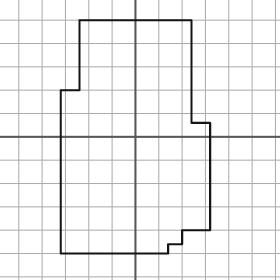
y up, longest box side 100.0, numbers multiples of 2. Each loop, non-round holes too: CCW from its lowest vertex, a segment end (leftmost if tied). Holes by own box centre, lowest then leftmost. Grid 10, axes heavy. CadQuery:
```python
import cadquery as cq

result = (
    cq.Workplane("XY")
    .moveTo(-32.0, -50.0)
    .lineTo(14.0, -50.0)
    .lineTo(14.0, -46.0)
    .lineTo(20.0, -46.0)
    .lineTo(20.0, -40.0)
    .lineTo(32.0, -40.0)
    .lineTo(32.0, 6.0)
    .lineTo(24.0, 6.0)
    .lineTo(24.0, 50.0)
    .lineTo(-24.0, 50.0)
    .lineTo(-24.0, 20.0)
    .lineTo(-32.0, 20.0)
    .close()
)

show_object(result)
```